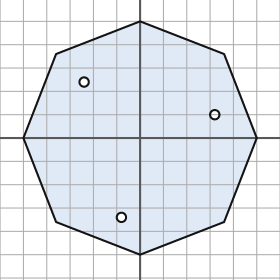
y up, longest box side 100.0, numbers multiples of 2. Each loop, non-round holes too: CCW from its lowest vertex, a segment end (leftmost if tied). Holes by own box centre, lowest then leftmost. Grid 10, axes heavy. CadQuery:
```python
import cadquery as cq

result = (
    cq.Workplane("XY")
    .moveTo(0.0, -50.0)
    .lineTo(36.0, -36.0)
    .lineTo(50.0, 0.0)
    .lineTo(36.0, 36.0)
    .lineTo(0.0, 50.0)
    .lineTo(-36.0, 36.0)
    .lineTo(-50.0, 0.0)
    .lineTo(-36.0, -36.0)
    .close()
    .moveTo(-8.0, -34.0)
    .circle(2.0)
    .moveTo(32.0, 10.0)
    .circle(2.0)
    .moveTo(-24.0, 24.0)
    .circle(2.0)
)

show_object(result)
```